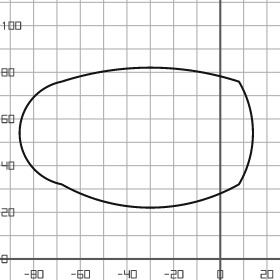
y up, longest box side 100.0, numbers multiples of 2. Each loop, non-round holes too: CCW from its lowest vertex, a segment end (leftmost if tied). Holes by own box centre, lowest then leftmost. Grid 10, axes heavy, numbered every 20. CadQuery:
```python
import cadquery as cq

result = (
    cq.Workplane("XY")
    .moveTo(-68.0, 32.0)
    .threePointArc((-30.0, 22.0), (8.0, 32.0))
    .threePointArc((14.0, 54.0), (8.0, 76.0))
    .threePointArc((-30.0, 82.0), (-68.0, 76.0))
    .threePointArc((-86.0, 54.0), (-68.0, 32.0))
    .close()
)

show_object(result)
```